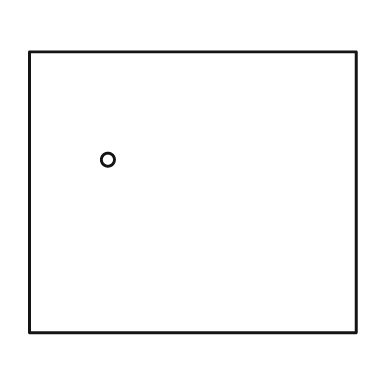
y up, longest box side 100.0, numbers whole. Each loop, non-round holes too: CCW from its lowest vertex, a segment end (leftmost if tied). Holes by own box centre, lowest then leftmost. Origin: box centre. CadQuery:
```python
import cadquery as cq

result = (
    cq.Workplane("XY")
    .moveTo(-50.0, -43.0)
    .lineTo(50.0, -43.0)
    .lineTo(50.0, 43.0)
    .lineTo(-50.0, 43.0)
    .close()
    .moveTo(-26.0, 10.0)
    .circle(2.0)
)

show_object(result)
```